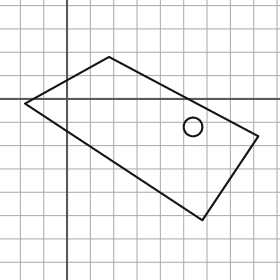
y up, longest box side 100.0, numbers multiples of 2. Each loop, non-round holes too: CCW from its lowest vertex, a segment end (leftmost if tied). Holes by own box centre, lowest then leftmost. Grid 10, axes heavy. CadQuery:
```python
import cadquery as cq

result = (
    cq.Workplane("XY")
    .moveTo(58.0, -52.0)
    .lineTo(82.0, -16.0)
    .lineTo(18.0, 18.0)
    .lineTo(-18.0, -2.0)
    .close()
    .moveTo(54.0, -12.0)
    .circle(4.0)
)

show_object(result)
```